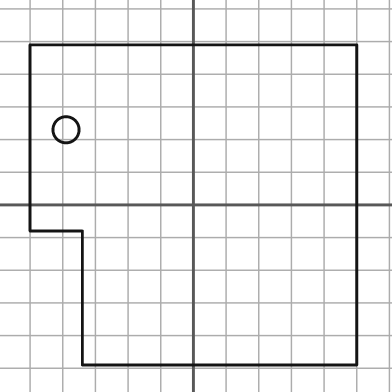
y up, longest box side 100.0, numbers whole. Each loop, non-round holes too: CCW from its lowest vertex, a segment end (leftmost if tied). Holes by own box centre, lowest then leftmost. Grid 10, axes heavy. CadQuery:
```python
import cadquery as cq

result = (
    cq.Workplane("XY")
    .moveTo(-34.0, -49.0)
    .lineTo(50.0, -49.0)
    .lineTo(50.0, 49.0)
    .lineTo(-50.0, 49.0)
    .lineTo(-50.0, -8.0)
    .lineTo(-34.0, -8.0)
    .close()
    .moveTo(-39.0, 23.0)
    .circle(4.0)
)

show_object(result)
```